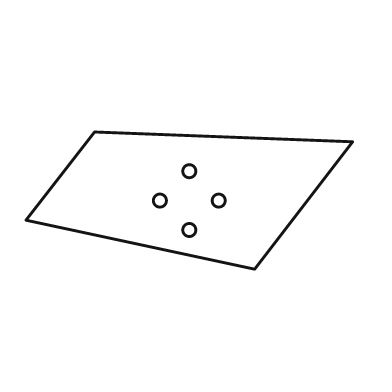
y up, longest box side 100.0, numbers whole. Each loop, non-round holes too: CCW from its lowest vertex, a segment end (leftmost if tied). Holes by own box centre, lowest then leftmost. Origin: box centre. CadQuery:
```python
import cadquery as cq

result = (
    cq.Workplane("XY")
    .moveTo(20.0, -21.0)
    .lineTo(50.0, 18.0)
    .lineTo(-29.0, 21.0)
    .lineTo(-50.0, -6.0)
    .close()
    .moveTo(0.0, -9.0)
    .circle(2.0)
    .moveTo(-9.0, 0.0)
    .circle(2.0)
    .moveTo(9.0, 0.0)
    .circle(2.0)
    .moveTo(0.0, 9.0)
    .circle(2.0)
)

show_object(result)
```